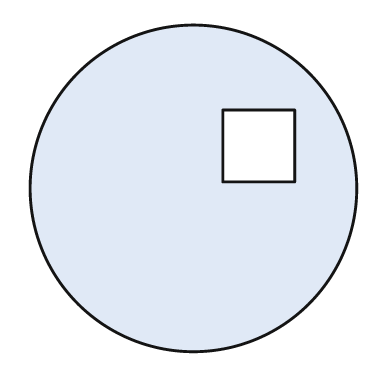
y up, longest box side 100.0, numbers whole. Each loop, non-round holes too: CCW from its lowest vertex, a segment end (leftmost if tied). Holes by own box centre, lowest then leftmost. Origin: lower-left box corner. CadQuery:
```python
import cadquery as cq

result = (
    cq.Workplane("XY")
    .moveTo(50.0, 50.0)
    .circle(50.0)
    .moveTo(59.0, 52.0)
    .lineTo(81.0, 52.0)
    .lineTo(81.0, 74.0)
    .lineTo(59.0, 74.0)
    .close()
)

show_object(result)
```